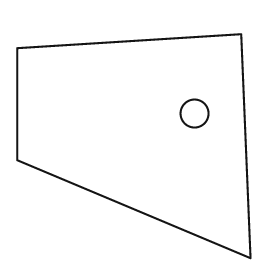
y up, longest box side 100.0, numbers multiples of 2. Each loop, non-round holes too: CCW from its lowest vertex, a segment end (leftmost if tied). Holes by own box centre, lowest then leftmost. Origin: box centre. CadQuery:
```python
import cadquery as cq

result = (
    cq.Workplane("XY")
    .moveTo(50.0, -48.0)
    .lineTo(46.0, 48.0)
    .lineTo(-50.0, 42.0)
    .lineTo(-50.0, -6.0)
    .close()
    .moveTo(26.0, 14.0)
    .circle(6.0)
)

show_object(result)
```